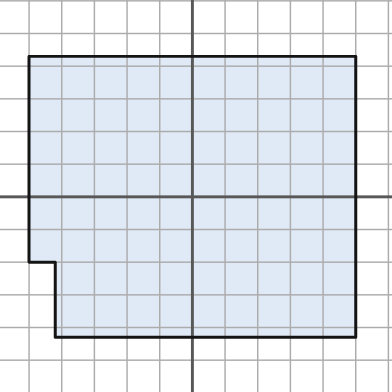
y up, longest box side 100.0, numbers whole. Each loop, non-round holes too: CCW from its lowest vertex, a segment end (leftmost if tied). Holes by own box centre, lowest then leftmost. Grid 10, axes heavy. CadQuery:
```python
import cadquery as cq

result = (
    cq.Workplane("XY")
    .moveTo(-42.0, -43.0)
    .lineTo(50.0, -43.0)
    .lineTo(50.0, 43.0)
    .lineTo(-50.0, 43.0)
    .lineTo(-50.0, -20.0)
    .lineTo(-42.0, -20.0)
    .close()
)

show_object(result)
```